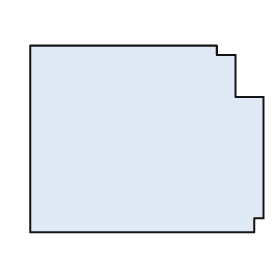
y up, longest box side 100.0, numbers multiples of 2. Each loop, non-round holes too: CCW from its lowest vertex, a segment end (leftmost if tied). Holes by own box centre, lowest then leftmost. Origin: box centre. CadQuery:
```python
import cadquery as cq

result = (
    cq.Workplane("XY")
    .moveTo(-50.0, -40.0)
    .lineTo(46.0, -40.0)
    .lineTo(46.0, -34.0)
    .lineTo(50.0, -34.0)
    .lineTo(50.0, 18.0)
    .lineTo(38.0, 18.0)
    .lineTo(38.0, 36.0)
    .lineTo(30.0, 36.0)
    .lineTo(30.0, 40.0)
    .lineTo(-50.0, 40.0)
    .close()
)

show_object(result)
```